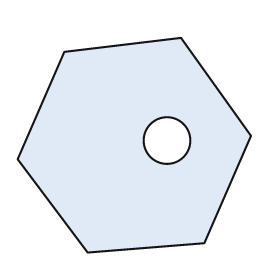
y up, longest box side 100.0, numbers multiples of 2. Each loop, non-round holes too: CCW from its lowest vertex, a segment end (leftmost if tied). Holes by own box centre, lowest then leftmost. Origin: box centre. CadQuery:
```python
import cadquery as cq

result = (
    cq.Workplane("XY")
    .moveTo(-20.0, -46.0)
    .lineTo(30.0, -42.0)
    .lineTo(50.0, 4.0)
    .lineTo(20.0, 46.0)
    .lineTo(-30.0, 40.0)
    .lineTo(-50.0, -6.0)
    .close()
    .moveTo(14.0, 2.0)
    .circle(10.0)
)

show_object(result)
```